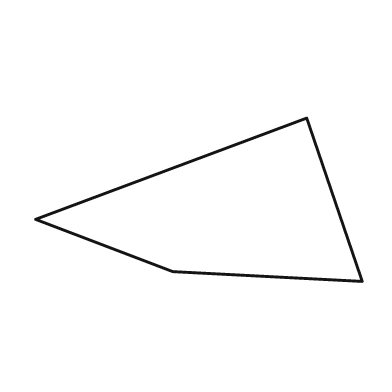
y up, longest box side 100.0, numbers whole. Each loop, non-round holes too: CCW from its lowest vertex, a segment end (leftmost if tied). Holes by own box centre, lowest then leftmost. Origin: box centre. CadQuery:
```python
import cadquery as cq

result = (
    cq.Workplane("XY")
    .moveTo(50.0, -25.0)
    .lineTo(33.0, 25.0)
    .lineTo(-50.0, -6.0)
    .lineTo(-8.0, -22.0)
    .close()
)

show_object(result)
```